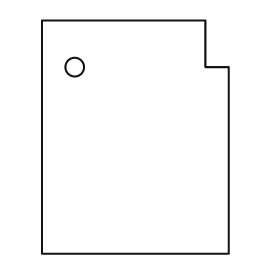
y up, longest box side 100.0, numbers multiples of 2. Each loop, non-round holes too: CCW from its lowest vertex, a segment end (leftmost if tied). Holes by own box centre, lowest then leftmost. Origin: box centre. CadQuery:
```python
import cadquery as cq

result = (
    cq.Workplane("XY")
    .moveTo(-40.0, -50.0)
    .lineTo(40.0, -50.0)
    .lineTo(40.0, 30.0)
    .lineTo(30.0, 30.0)
    .lineTo(30.0, 50.0)
    .lineTo(-40.0, 50.0)
    .close()
    .moveTo(-26.0, 30.0)
    .circle(4.0)
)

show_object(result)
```